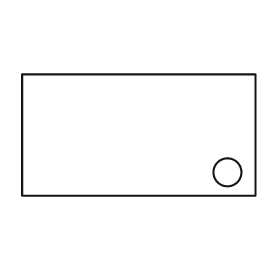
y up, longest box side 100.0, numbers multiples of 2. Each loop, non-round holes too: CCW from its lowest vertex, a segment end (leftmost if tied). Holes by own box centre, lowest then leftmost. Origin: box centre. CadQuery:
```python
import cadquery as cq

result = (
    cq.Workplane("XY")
    .moveTo(-50.0, -26.0)
    .lineTo(50.0, -26.0)
    .lineTo(50.0, 26.0)
    .lineTo(-50.0, 26.0)
    .close()
    .moveTo(38.0, -16.0)
    .circle(6.0)
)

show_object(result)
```